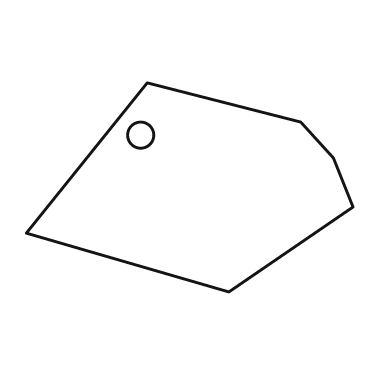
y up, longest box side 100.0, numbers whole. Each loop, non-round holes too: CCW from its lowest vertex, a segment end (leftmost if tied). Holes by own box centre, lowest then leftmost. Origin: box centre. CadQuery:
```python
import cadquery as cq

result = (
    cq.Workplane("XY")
    .moveTo(12.0, -32.0)
    .lineTo(50.0, -6.0)
    .lineTo(44.0, 9.0)
    .lineTo(34.0, 20.0)
    .lineTo(-13.0, 32.0)
    .lineTo(-50.0, -14.0)
    .close()
    .moveTo(-15.0, 16.0)
    .circle(4.0)
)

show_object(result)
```